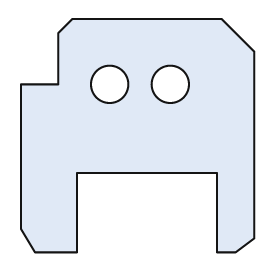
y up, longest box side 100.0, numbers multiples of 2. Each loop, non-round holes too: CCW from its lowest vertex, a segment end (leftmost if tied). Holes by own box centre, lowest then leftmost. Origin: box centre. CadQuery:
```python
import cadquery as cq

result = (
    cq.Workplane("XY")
    .moveTo(-44.0, -50.0)
    .lineTo(-26.0, -50.0)
    .lineTo(-26.0, -16.0)
    .lineTo(34.0, -16.0)
    .lineTo(34.0, -50.0)
    .lineTo(42.0, -50.0)
    .lineTo(50.0, -44.0)
    .lineTo(50.0, 36.0)
    .lineTo(36.0, 50.0)
    .lineTo(-28.0, 50.0)
    .lineTo(-34.0, 44.0)
    .lineTo(-34.0, 22.0)
    .lineTo(-50.0, 22.0)
    .lineTo(-50.0, -40.0)
    .close()
    .moveTo(-12.0, 22.0)
    .circle(8.0)
    .moveTo(14.0, 22.0)
    .circle(8.0)
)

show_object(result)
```